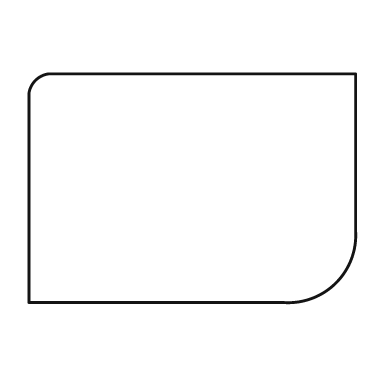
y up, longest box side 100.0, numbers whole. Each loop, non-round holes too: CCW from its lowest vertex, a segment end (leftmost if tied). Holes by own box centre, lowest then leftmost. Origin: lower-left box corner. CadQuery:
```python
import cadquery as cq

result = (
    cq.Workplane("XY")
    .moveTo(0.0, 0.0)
    .lineTo(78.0, 0.0)
    .threePointArc((94.0, 6.0), (100.0, 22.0))
    .lineTo(100.0, 70.0)
    .lineTo(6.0, 70.0)
    .threePointArc((2.0, 68.0), (0.0, 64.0))
    .close()
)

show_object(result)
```